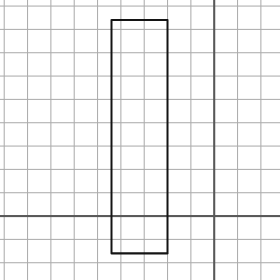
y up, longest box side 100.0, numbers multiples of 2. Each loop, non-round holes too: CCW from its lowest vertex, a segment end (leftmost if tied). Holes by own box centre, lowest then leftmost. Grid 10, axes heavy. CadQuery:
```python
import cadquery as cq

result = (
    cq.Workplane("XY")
    .moveTo(-44.0, -16.0)
    .lineTo(-20.0, -16.0)
    .lineTo(-20.0, 84.0)
    .lineTo(-44.0, 84.0)
    .close()
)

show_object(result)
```